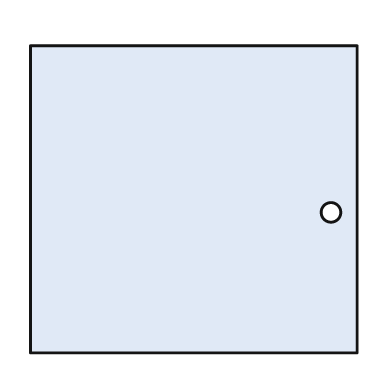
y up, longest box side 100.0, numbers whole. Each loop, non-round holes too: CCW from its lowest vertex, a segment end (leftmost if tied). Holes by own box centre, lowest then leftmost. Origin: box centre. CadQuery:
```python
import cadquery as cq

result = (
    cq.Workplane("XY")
    .moveTo(-50.0, -47.0)
    .lineTo(50.0, -47.0)
    .lineTo(50.0, 47.0)
    .lineTo(-50.0, 47.0)
    .close()
    .moveTo(42.0, -4.0)
    .circle(3.0)
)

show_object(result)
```